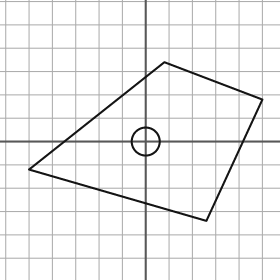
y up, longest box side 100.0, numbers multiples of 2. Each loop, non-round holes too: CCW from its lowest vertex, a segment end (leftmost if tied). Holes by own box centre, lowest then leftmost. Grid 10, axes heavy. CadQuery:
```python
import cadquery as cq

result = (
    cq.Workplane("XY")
    .moveTo(26.0, -34.0)
    .lineTo(50.0, 18.0)
    .lineTo(8.0, 34.0)
    .lineTo(-50.0, -12.0)
    .close()
    .moveTo(0.0, 0.0)
    .circle(6.0)
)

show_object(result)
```